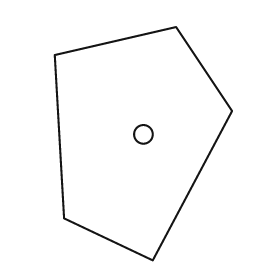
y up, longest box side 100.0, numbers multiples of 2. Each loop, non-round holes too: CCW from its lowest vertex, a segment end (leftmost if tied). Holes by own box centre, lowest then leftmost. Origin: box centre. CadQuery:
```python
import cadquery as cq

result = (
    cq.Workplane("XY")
    .moveTo(4.0, -50.0)
    .lineTo(38.0, 14.0)
    .lineTo(14.0, 50.0)
    .lineTo(-38.0, 38.0)
    .lineTo(-34.0, -32.0)
    .close()
    .moveTo(0.0, 4.0)
    .circle(4.0)
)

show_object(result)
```